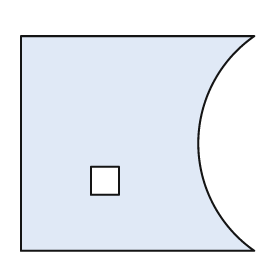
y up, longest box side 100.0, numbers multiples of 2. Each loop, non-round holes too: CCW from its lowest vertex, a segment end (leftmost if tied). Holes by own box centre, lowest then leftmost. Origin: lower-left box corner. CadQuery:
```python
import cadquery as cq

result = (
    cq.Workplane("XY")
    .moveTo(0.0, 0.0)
    .lineTo(100.0, 0.0)
    .threePointArc((76.0, 46.0), (100.0, 92.0))
    .lineTo(0.0, 92.0)
    .close()
    .moveTo(30.0, 24.0)
    .lineTo(42.0, 24.0)
    .lineTo(42.0, 36.0)
    .lineTo(30.0, 36.0)
    .close()
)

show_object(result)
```